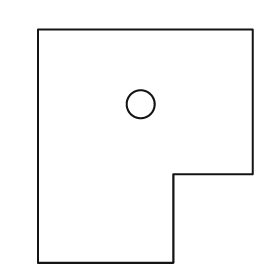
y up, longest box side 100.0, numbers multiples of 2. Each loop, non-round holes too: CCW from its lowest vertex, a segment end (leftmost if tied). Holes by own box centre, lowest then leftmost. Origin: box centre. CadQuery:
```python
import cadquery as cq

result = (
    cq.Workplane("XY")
    .moveTo(-46.0, -50.0)
    .lineTo(12.0, -50.0)
    .lineTo(12.0, -12.0)
    .lineTo(46.0, -12.0)
    .lineTo(46.0, 50.0)
    .lineTo(-46.0, 50.0)
    .close()
    .moveTo(-2.0, 18.0)
    .circle(6.0)
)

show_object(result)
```